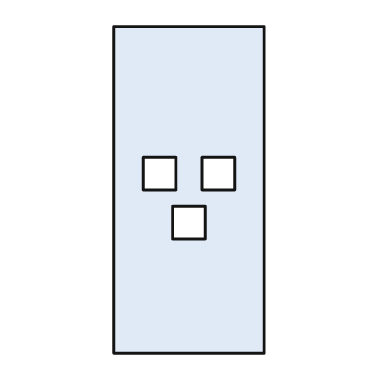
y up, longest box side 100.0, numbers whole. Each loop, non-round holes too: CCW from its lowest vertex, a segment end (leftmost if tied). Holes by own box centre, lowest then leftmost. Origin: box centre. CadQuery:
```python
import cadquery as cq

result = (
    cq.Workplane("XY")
    .moveTo(-23.0, -50.0)
    .lineTo(23.0, -50.0)
    .lineTo(23.0, 50.0)
    .lineTo(-23.0, 50.0)
    .close()
    .moveTo(-5.0, -15.0)
    .lineTo(5.0, -15.0)
    .lineTo(5.0, -5.0)
    .lineTo(-5.0, -5.0)
    .close()
    .moveTo(-14.0, 0.0)
    .lineTo(-4.0, 0.0)
    .lineTo(-4.0, 10.0)
    .lineTo(-14.0, 10.0)
    .close()
    .moveTo(4.0, 0.0)
    .lineTo(14.0, 0.0)
    .lineTo(14.0, 10.0)
    .lineTo(4.0, 10.0)
    .close()
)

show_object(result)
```